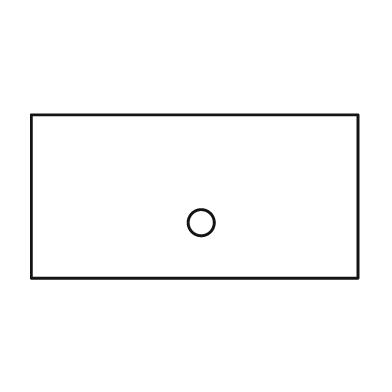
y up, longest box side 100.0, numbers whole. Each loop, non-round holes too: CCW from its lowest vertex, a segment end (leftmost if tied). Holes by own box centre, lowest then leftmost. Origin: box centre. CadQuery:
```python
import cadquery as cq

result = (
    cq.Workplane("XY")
    .moveTo(-50.0, -25.0)
    .lineTo(50.0, -25.0)
    .lineTo(50.0, 25.0)
    .lineTo(-50.0, 25.0)
    .close()
    .moveTo(2.0, -8.0)
    .circle(4.0)
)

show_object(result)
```